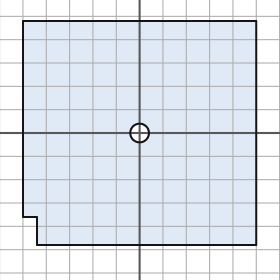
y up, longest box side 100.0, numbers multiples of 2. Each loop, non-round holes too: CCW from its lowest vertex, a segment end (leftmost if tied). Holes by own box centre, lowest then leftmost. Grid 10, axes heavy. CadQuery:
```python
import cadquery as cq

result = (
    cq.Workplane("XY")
    .moveTo(-44.0, -48.0)
    .lineTo(50.0, -48.0)
    .lineTo(50.0, 48.0)
    .lineTo(-50.0, 48.0)
    .lineTo(-50.0, -36.0)
    .lineTo(-44.0, -36.0)
    .close()
    .moveTo(0.0, 0.0)
    .circle(4.0)
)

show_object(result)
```